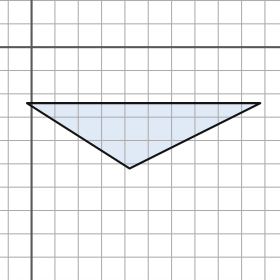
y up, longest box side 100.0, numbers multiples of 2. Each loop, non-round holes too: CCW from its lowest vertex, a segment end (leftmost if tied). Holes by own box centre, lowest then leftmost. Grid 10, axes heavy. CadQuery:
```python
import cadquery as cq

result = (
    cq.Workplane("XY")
    .moveTo(42.0, -52.0)
    .lineTo(98.0, -24.0)
    .lineTo(-2.0, -24.0)
    .close()
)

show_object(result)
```